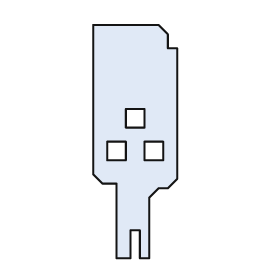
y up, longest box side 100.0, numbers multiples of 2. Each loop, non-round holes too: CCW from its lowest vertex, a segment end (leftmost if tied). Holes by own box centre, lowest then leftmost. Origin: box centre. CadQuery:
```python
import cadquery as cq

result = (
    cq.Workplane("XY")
    .moveTo(-8.0, -50.0)
    .lineTo(-2.0, -50.0)
    .lineTo(-2.0, -38.0)
    .lineTo(2.0, -38.0)
    .lineTo(2.0, -50.0)
    .lineTo(6.0, -50.0)
    .lineTo(6.0, -24.0)
    .lineTo(10.0, -20.0)
    .lineTo(14.0, -20.0)
    .lineTo(18.0, -16.0)
    .lineTo(18.0, 40.0)
    .lineTo(14.0, 40.0)
    .lineTo(14.0, 46.0)
    .lineTo(10.0, 50.0)
    .lineTo(-18.0, 50.0)
    .lineTo(-18.0, -14.0)
    .lineTo(-14.0, -18.0)
    .lineTo(-8.0, -18.0)
    .close()
    .moveTo(-12.0, -8.0)
    .lineTo(-4.0, -8.0)
    .lineTo(-4.0, 0.0)
    .lineTo(-12.0, 0.0)
    .close()
    .moveTo(4.0, -8.0)
    .lineTo(12.0, -8.0)
    .lineTo(12.0, 0.0)
    .lineTo(4.0, 0.0)
    .close()
    .moveTo(-4.0, 6.0)
    .lineTo(4.0, 6.0)
    .lineTo(4.0, 14.0)
    .lineTo(-4.0, 14.0)
    .close()
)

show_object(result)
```